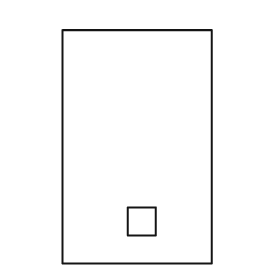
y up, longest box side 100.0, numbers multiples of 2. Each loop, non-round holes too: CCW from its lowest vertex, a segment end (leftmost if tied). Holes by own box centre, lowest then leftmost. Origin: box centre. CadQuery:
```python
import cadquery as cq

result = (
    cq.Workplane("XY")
    .moveTo(-32.0, -50.0)
    .lineTo(32.0, -50.0)
    .lineTo(32.0, 50.0)
    .lineTo(-32.0, 50.0)
    .close()
    .moveTo(-4.0, -38.0)
    .lineTo(8.0, -38.0)
    .lineTo(8.0, -26.0)
    .lineTo(-4.0, -26.0)
    .close()
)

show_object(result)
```